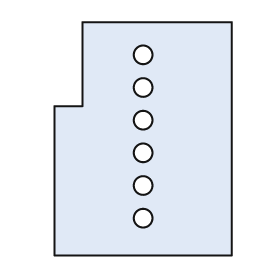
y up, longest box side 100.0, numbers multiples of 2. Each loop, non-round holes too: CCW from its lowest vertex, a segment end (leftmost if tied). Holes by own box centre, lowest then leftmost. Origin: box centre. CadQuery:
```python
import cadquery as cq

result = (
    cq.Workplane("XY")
    .moveTo(-38.0, -50.0)
    .lineTo(38.0, -50.0)
    .lineTo(38.0, 50.0)
    .lineTo(-26.0, 50.0)
    .lineTo(-26.0, 14.0)
    .lineTo(-38.0, 14.0)
    .close()
    .moveTo(0.0, -34.0)
    .circle(4.0)
    .moveTo(0.0, -20.0)
    .circle(4.0)
    .moveTo(0.0, -6.0)
    .circle(4.0)
    .moveTo(0.0, 8.0)
    .circle(4.0)
    .moveTo(0.0, 22.0)
    .circle(4.0)
    .moveTo(0.0, 36.0)
    .circle(4.0)
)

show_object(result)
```